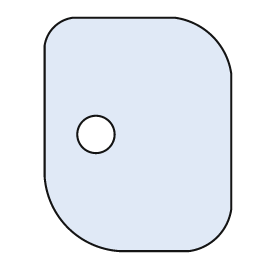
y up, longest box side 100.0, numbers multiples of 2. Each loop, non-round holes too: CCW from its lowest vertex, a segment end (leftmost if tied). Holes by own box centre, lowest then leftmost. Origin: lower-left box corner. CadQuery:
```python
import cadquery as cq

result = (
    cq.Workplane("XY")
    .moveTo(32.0, 0.0)
    .lineTo(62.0, 0.0)
    .threePointArc((74.0, 6.0), (80.0, 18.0))
    .lineTo(80.0, 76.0)
    .threePointArc((72.0, 92.0), (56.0, 100.0))
    .lineTo(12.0, 100.0)
    .threePointArc((4.0, 96.0), (0.0, 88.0))
    .lineTo(0.0, 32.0)
    .threePointArc((10.0, 10.0), (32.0, 0.0))
    .close()
    .moveTo(22.0, 50.0)
    .circle(8.0)
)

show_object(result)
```